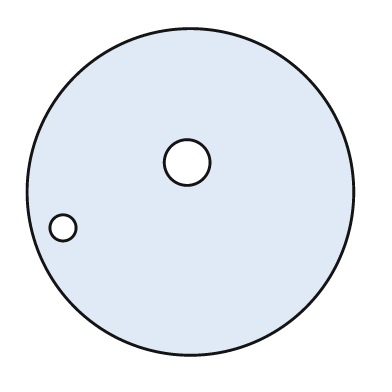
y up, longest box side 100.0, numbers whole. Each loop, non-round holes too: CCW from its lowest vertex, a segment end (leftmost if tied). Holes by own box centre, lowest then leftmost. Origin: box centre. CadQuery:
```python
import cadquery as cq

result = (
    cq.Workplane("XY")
    .moveTo(0.0, 0.0)
    .circle(50.0)
    .moveTo(-39.0, -11.0)
    .circle(4.0)
    .moveTo(-1.0, 9.0)
    .circle(7.0)
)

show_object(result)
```